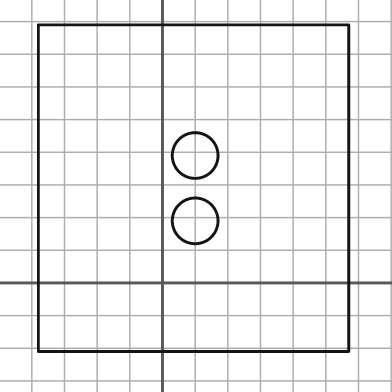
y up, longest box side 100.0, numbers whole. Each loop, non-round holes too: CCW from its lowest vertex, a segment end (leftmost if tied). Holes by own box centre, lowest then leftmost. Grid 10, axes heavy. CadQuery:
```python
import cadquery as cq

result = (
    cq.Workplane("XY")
    .moveTo(-38.0, -21.0)
    .lineTo(57.0, -21.0)
    .lineTo(57.0, 79.0)
    .lineTo(-38.0, 79.0)
    .close()
    .moveTo(10.0, 19.0)
    .circle(7.0)
    .moveTo(10.0, 39.0)
    .circle(7.0)
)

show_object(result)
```